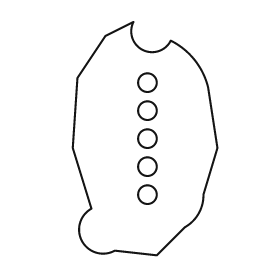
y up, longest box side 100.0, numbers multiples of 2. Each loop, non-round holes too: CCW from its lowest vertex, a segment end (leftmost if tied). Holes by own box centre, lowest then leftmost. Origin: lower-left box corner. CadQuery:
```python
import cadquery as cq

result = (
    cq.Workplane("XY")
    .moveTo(36.0, 0.0)
    .lineTo(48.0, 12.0)
    .threePointArc((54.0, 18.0), (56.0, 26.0))
    .lineTo(62.0, 46.0)
    .lineTo(58.0, 72.0)
    .threePointArc((52.0, 84.0), (42.0, 92.0))
    .threePointArc((30.0, 88.0), (26.0, 100.0))
    .lineTo(14.0, 94.0)
    .lineTo(2.0, 76.0)
    .lineTo(0.0, 46.0)
    .lineTo(8.0, 20.0)
    .threePointArc((4.0, 6.0), (18.0, 2.0))
    .close()
    .moveTo(32.0, 26.0)
    .circle(4.0)
    .moveTo(32.0, 38.0)
    .circle(4.0)
    .moveTo(32.0, 50.0)
    .circle(4.0)
    .moveTo(32.0, 62.0)
    .circle(4.0)
    .moveTo(32.0, 74.0)
    .circle(4.0)
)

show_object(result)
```